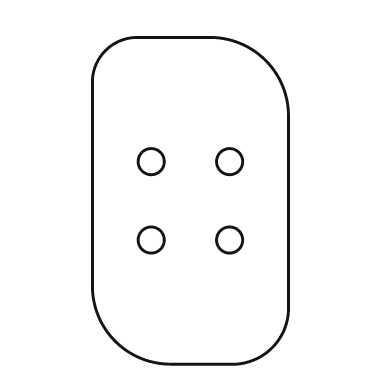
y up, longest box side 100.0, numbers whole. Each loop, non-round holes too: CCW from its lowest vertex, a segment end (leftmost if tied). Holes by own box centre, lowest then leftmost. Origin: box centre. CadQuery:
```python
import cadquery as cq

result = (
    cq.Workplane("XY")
    .moveTo(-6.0, -50.0)
    .lineTo(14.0, -50.0)
    .threePointArc((25.0, -45.0), (30.0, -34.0))
    .lineTo(30.0, 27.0)
    .threePointArc((23.0, 43.0), (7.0, 50.0))
    .lineTo(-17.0, 50.0)
    .threePointArc((-26.0, 46.0), (-30.0, 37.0))
    .lineTo(-30.0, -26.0)
    .threePointArc((-23.0, -43.0), (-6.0, -50.0))
    .close()
    .moveTo(-12.0, -12.0)
    .circle(4.0)
    .moveTo(12.0, -12.0)
    .circle(4.0)
    .moveTo(-12.0, 12.0)
    .circle(4.0)
    .moveTo(12.0, 12.0)
    .circle(4.0)
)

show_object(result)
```